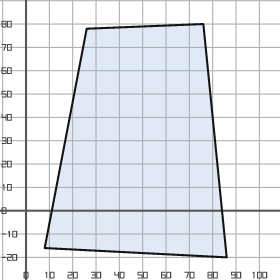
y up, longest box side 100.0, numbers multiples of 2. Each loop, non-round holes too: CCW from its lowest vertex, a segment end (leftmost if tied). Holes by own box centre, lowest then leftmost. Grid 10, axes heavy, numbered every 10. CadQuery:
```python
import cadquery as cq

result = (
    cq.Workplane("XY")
    .moveTo(86.0, -20.0)
    .lineTo(76.0, 80.0)
    .lineTo(26.0, 78.0)
    .lineTo(8.0, -16.0)
    .close()
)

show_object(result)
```